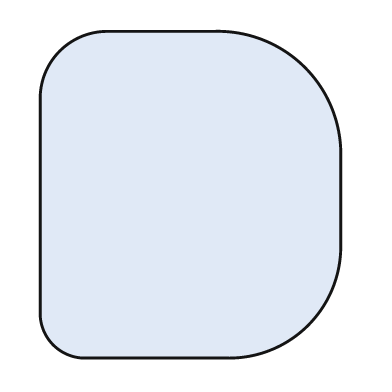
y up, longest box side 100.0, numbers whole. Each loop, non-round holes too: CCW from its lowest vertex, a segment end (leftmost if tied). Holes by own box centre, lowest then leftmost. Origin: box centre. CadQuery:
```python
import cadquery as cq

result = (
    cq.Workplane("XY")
    .moveTo(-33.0, -50.0)
    .lineTo(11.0, -50.0)
    .threePointArc((36.0, -40.0), (46.0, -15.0))
    .lineTo(46.0, 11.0)
    .threePointArc((35.0, 39.0), (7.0, 50.0))
    .lineTo(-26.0, 50.0)
    .threePointArc((-40.0, 44.0), (-46.0, 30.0))
    .lineTo(-46.0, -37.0)
    .threePointArc((-42.0, -46.0), (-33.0, -50.0))
    .close()
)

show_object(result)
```